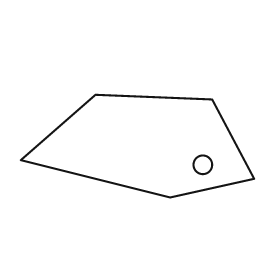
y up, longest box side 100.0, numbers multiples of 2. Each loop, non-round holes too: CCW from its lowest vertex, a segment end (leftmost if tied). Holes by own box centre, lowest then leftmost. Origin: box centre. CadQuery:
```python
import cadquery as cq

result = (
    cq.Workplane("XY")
    .moveTo(14.0, -22.0)
    .lineTo(50.0, -14.0)
    .lineTo(32.0, 20.0)
    .lineTo(-18.0, 22.0)
    .lineTo(-50.0, -6.0)
    .close()
    .moveTo(28.0, -8.0)
    .circle(4.0)
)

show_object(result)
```